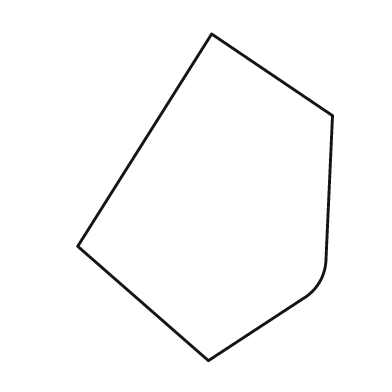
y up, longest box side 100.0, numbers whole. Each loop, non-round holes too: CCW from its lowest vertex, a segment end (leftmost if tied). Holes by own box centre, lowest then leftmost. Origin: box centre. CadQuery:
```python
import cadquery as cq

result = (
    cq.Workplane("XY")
    .moveTo(1.0, -50.0)
    .lineTo(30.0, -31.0)
    .threePointArc((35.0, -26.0), (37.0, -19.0))
    .lineTo(39.0, 25.0)
    .lineTo(2.0, 50.0)
    .lineTo(-39.0, -15.0)
    .close()
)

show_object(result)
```